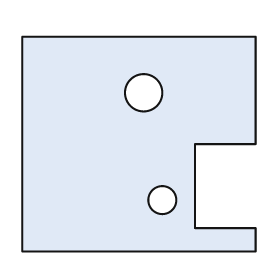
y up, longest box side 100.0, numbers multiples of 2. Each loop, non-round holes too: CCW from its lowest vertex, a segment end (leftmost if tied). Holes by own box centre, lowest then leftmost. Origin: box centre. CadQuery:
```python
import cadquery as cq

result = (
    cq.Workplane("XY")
    .moveTo(-50.0, -46.0)
    .lineTo(50.0, -46.0)
    .lineTo(50.0, -36.0)
    .lineTo(24.0, -36.0)
    .lineTo(24.0, 0.0)
    .lineTo(50.0, 0.0)
    .lineTo(50.0, 46.0)
    .lineTo(-50.0, 46.0)
    .close()
    .moveTo(10.0, -24.0)
    .circle(6.0)
    .moveTo(2.0, 22.0)
    .circle(8.0)
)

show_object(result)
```